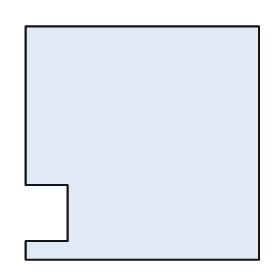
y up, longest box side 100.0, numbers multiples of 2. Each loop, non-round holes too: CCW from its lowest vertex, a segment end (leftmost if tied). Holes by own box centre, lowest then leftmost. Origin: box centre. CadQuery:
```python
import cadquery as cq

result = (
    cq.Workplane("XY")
    .moveTo(-50.0, -50.0)
    .lineTo(50.0, -50.0)
    .lineTo(50.0, 50.0)
    .lineTo(-50.0, 50.0)
    .lineTo(-50.0, -18.0)
    .lineTo(-32.0, -18.0)
    .lineTo(-32.0, -42.0)
    .lineTo(-50.0, -42.0)
    .close()
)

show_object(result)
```